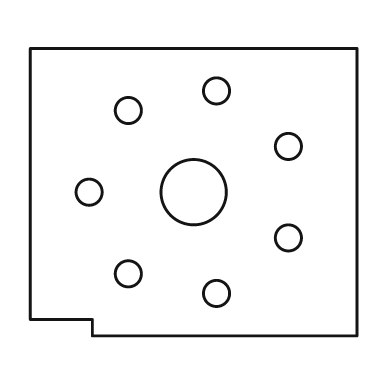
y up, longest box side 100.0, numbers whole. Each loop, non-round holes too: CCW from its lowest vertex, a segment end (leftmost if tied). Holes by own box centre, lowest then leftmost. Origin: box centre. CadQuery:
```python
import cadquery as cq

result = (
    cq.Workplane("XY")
    .moveTo(-31.0, -44.0)
    .lineTo(50.0, -44.0)
    .lineTo(50.0, 44.0)
    .lineTo(-50.0, 44.0)
    .lineTo(-50.0, -39.0)
    .lineTo(-31.0, -39.0)
    .close()
    .moveTo(7.0, -31.0)
    .circle(4.0)
    .moveTo(-20.0, -25.0)
    .circle(4.0)
    .moveTo(29.0, -14.0)
    .circle(4.0)
    .moveTo(-32.0, 0.0)
    .circle(4.0)
    .moveTo(0.0, 0.0)
    .circle(10.0)
    .moveTo(29.0, 14.0)
    .circle(4.0)
    .moveTo(-20.0, 25.0)
    .circle(4.0)
    .moveTo(7.0, 31.0)
    .circle(4.0)
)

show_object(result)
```